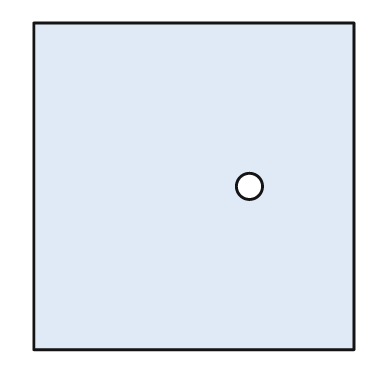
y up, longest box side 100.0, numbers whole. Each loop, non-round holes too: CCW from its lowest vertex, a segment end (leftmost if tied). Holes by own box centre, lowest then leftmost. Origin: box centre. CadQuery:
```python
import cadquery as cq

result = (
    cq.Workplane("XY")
    .moveTo(-49.0, -50.0)
    .lineTo(49.0, -50.0)
    .lineTo(49.0, 50.0)
    .lineTo(-49.0, 50.0)
    .close()
    .moveTo(17.0, 0.0)
    .circle(4.0)
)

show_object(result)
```